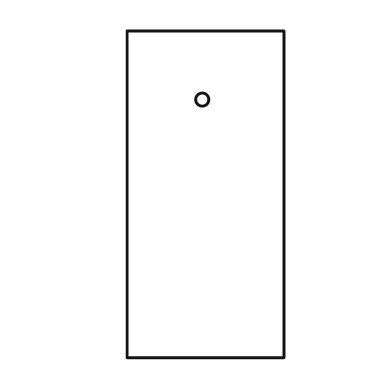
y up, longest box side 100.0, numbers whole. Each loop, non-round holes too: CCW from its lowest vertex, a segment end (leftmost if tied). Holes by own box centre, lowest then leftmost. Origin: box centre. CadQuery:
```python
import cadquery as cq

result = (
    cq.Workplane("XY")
    .moveTo(-24.0, -50.0)
    .lineTo(24.0, -50.0)
    .lineTo(24.0, 50.0)
    .lineTo(-24.0, 50.0)
    .close()
    .moveTo(-1.0, 29.0)
    .circle(2.0)
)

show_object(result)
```